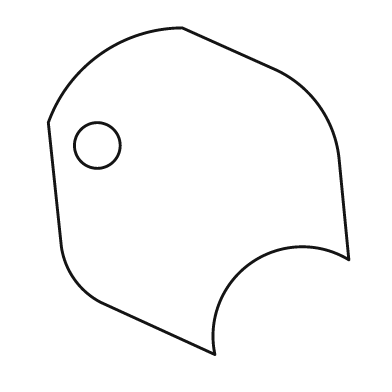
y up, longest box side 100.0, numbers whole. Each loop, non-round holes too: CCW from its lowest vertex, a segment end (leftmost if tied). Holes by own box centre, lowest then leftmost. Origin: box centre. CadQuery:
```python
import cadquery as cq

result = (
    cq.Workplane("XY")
    .moveTo(5.0, -50.0)
    .threePointArc((16.0, -22.0), (46.0, -21.0))
    .lineTo(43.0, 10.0)
    .threePointArc((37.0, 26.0), (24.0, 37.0))
    .lineTo(-5.0, 50.0)
    .threePointArc((-30.0, 42.0), (-46.0, 21.0))
    .lineTo(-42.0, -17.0)
    .threePointArc((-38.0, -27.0), (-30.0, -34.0))
    .close()
    .moveTo(-31.0, 14.0)
    .circle(7.0)
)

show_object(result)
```